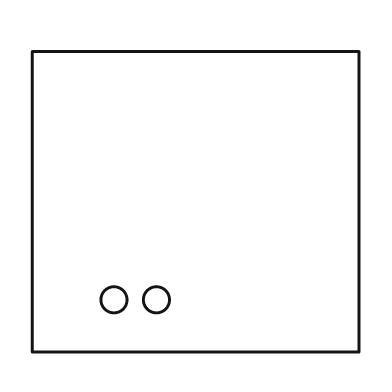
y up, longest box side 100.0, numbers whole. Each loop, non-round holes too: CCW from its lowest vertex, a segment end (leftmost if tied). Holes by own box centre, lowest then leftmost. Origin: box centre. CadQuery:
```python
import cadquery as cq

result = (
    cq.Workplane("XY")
    .moveTo(-50.0, -46.0)
    .lineTo(50.0, -46.0)
    .lineTo(50.0, 46.0)
    .lineTo(-50.0, 46.0)
    .close()
    .moveTo(-25.0, -30.0)
    .circle(4.0)
    .moveTo(-12.0, -30.0)
    .circle(4.0)
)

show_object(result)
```